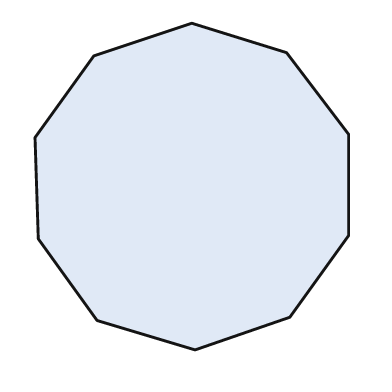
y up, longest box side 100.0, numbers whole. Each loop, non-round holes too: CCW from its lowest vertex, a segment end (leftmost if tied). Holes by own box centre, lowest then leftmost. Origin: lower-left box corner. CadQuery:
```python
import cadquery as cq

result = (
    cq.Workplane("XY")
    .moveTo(49.0, 0.0)
    .lineTo(78.0, 10.0)
    .lineTo(96.0, 35.0)
    .lineTo(96.0, 66.0)
    .lineTo(77.0, 91.0)
    .lineTo(48.0, 100.0)
    .lineTo(18.0, 90.0)
    .lineTo(0.0, 65.0)
    .lineTo(1.0, 34.0)
    .lineTo(19.0, 9.0)
    .close()
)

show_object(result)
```